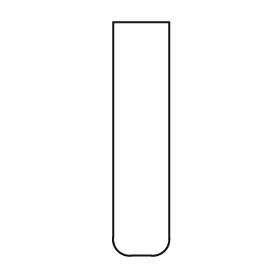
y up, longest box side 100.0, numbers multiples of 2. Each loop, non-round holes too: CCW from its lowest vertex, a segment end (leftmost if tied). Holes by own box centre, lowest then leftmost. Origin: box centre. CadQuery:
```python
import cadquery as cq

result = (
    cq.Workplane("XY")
    .moveTo(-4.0, -50.0)
    .lineTo(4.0, -50.0)
    .threePointArc((10.0, -48.0), (12.0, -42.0))
    .lineTo(12.0, 50.0)
    .lineTo(-12.0, 50.0)
    .lineTo(-12.0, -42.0)
    .threePointArc((-10.0, -48.0), (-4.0, -50.0))
    .close()
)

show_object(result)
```